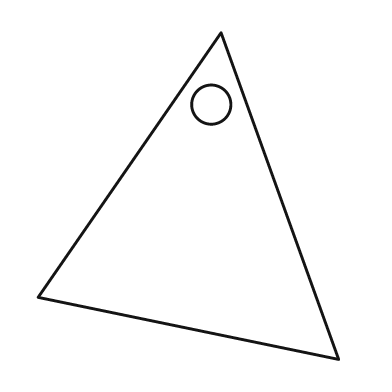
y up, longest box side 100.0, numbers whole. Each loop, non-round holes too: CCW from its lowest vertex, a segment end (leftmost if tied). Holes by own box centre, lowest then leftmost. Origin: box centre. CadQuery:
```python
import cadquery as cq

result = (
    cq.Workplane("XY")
    .moveTo(46.0, -50.0)
    .lineTo(10.0, 50.0)
    .lineTo(-46.0, -31.0)
    .close()
    .moveTo(7.0, 28.0)
    .circle(6.0)
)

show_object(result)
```